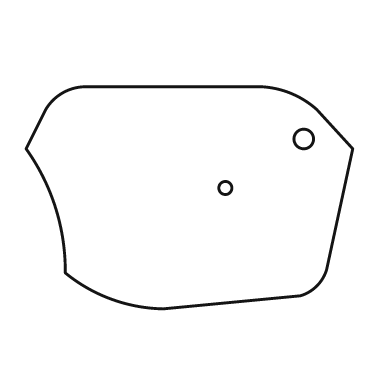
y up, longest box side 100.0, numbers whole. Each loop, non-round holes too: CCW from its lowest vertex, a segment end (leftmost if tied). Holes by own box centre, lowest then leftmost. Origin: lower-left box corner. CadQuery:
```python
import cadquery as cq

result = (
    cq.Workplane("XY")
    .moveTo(42.0, 0.0)
    .lineTo(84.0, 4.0)
    .threePointArc((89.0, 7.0), (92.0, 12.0))
    .lineTo(100.0, 49.0)
    .lineTo(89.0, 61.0)
    .threePointArc((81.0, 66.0), (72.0, 68.0))
    .lineTo(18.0, 68.0)
    .threePointArc((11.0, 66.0), (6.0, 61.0))
    .lineTo(0.0, 49.0)
    .threePointArc((9.0, 31.0), (12.0, 11.0))
    .threePointArc((26.0, 3.0), (42.0, 0.0))
    .close()
    .moveTo(61.0, 37.0)
    .circle(2.0)
    .moveTo(85.0, 52.0)
    .circle(3.0)
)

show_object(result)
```